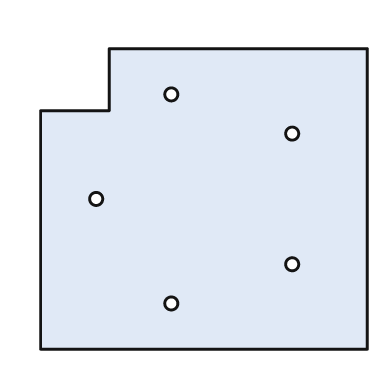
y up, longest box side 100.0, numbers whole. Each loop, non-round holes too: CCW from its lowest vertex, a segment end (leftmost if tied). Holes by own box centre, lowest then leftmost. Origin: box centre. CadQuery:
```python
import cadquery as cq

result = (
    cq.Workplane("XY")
    .moveTo(-50.0, -46.0)
    .lineTo(50.0, -46.0)
    .lineTo(50.0, 46.0)
    .lineTo(-29.0, 46.0)
    .lineTo(-29.0, 27.0)
    .lineTo(-50.0, 27.0)
    .close()
    .moveTo(-10.0, -32.0)
    .circle(2.0)
    .moveTo(27.0, -20.0)
    .circle(2.0)
    .moveTo(-33.0, 0.0)
    .circle(2.0)
    .moveTo(27.0, 20.0)
    .circle(2.0)
    .moveTo(-10.0, 32.0)
    .circle(2.0)
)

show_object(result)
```